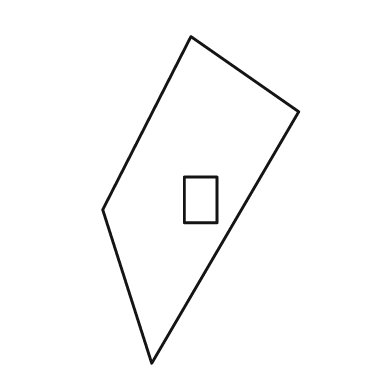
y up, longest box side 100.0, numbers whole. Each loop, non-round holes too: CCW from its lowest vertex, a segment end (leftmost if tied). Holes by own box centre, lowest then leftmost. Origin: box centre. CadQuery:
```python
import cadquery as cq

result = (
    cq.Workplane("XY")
    .moveTo(-15.0, -50.0)
    .lineTo(30.0, 27.0)
    .lineTo(-3.0, 50.0)
    .lineTo(-30.0, -3.0)
    .close()
    .moveTo(-5.0, -7.0)
    .lineTo(5.0, -7.0)
    .lineTo(5.0, 7.0)
    .lineTo(-5.0, 7.0)
    .close()
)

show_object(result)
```